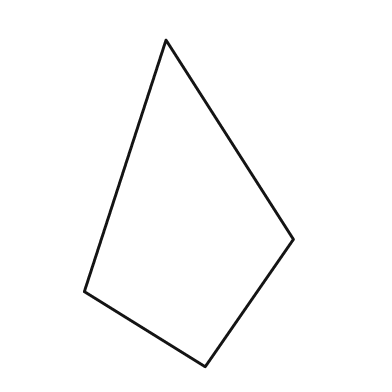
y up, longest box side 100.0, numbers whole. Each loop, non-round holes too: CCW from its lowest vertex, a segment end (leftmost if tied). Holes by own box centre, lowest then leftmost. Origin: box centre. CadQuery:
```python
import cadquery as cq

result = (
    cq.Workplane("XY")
    .moveTo(5.0, -50.0)
    .lineTo(32.0, -11.0)
    .lineTo(-7.0, 50.0)
    .lineTo(-32.0, -27.0)
    .close()
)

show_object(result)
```